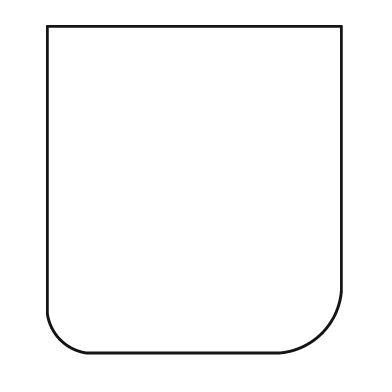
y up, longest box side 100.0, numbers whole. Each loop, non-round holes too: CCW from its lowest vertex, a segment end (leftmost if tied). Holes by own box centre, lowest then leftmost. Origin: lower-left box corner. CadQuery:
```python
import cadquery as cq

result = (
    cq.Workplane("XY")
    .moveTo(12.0, 0.0)
    .lineTo(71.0, 0.0)
    .threePointArc((84.0, 6.0), (90.0, 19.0))
    .lineTo(90.0, 100.0)
    .lineTo(0.0, 100.0)
    .lineTo(0.0, 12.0)
    .threePointArc((4.0, 4.0), (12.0, 0.0))
    .close()
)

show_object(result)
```